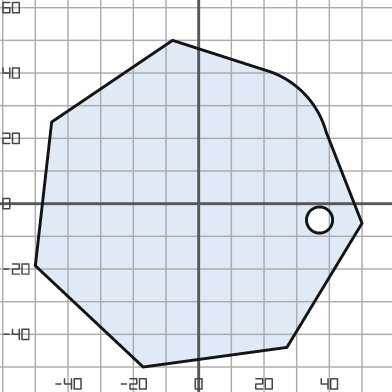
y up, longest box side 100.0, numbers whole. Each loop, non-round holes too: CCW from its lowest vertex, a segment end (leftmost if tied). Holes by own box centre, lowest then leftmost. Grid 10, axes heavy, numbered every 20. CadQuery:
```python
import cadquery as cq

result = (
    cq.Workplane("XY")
    .moveTo(-17.0, -50.0)
    .lineTo(27.0, -44.0)
    .lineTo(50.0, -6.0)
    .lineTo(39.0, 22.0)
    .threePointArc((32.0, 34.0), (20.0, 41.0))
    .lineTo(-8.0, 50.0)
    .lineTo(-45.0, 25.0)
    .lineTo(-50.0, -19.0)
    .close()
    .moveTo(37.0, -5.0)
    .circle(4.0)
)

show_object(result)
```